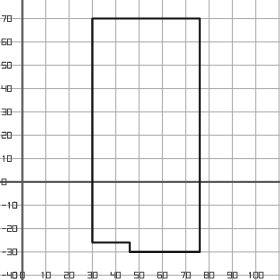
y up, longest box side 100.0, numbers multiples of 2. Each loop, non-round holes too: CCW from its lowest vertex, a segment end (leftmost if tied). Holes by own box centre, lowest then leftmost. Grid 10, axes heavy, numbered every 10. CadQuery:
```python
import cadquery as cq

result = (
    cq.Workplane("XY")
    .moveTo(46.0, -30.0)
    .lineTo(76.0, -30.0)
    .lineTo(76.0, 70.0)
    .lineTo(30.0, 70.0)
    .lineTo(30.0, -26.0)
    .lineTo(46.0, -26.0)
    .close()
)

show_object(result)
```